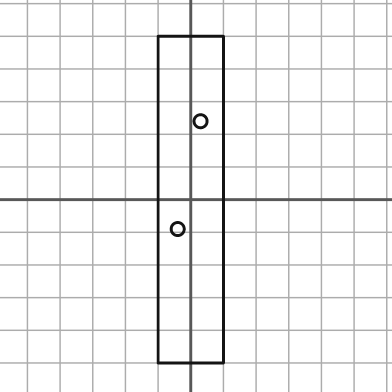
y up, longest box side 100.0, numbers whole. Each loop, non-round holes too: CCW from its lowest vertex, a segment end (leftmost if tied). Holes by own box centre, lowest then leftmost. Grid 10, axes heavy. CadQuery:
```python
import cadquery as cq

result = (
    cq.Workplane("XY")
    .moveTo(-10.0, -50.0)
    .lineTo(10.0, -50.0)
    .lineTo(10.0, 50.0)
    .lineTo(-10.0, 50.0)
    .close()
    .moveTo(-4.0, -9.0)
    .circle(2.0)
    .moveTo(3.0, 24.0)
    .circle(2.0)
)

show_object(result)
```